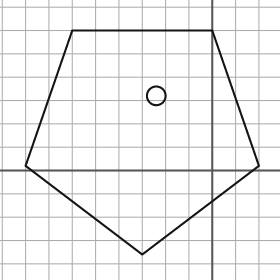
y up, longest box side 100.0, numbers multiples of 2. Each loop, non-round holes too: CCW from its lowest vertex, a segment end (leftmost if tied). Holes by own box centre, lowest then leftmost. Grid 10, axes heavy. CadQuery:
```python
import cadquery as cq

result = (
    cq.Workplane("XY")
    .moveTo(-30.0, -36.0)
    .lineTo(20.0, 2.0)
    .lineTo(0.0, 60.0)
    .lineTo(-60.0, 60.0)
    .lineTo(-80.0, 2.0)
    .close()
    .moveTo(-24.0, 32.0)
    .circle(4.0)
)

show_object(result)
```